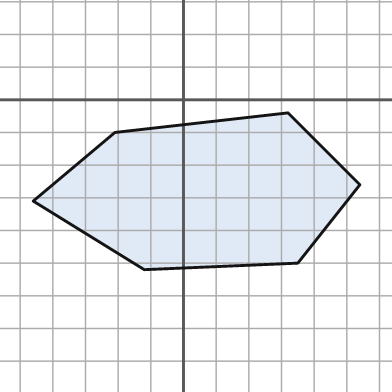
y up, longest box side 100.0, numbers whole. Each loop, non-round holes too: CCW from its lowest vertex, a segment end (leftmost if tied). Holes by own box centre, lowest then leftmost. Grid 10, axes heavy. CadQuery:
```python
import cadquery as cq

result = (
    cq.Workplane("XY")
    .moveTo(-12.0, -52.0)
    .lineTo(35.0, -50.0)
    .lineTo(54.0, -26.0)
    .lineTo(32.0, -4.0)
    .lineTo(-21.0, -10.0)
    .lineTo(-46.0, -31.0)
    .close()
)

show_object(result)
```